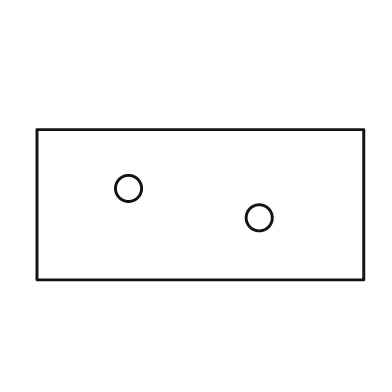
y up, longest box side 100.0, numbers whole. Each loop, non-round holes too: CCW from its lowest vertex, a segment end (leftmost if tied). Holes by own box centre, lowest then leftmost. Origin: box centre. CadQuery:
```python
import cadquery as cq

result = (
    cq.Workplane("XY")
    .moveTo(-50.0, -23.0)
    .lineTo(50.0, -23.0)
    .lineTo(50.0, 23.0)
    .lineTo(-50.0, 23.0)
    .close()
    .moveTo(18.0, -4.0)
    .circle(4.0)
    .moveTo(-22.0, 5.0)
    .circle(4.0)
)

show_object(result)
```